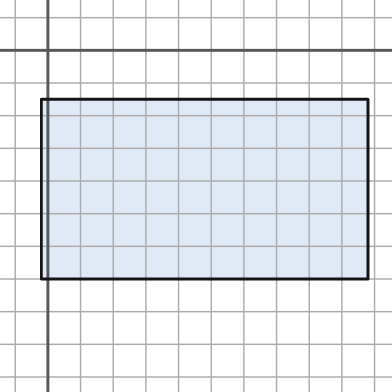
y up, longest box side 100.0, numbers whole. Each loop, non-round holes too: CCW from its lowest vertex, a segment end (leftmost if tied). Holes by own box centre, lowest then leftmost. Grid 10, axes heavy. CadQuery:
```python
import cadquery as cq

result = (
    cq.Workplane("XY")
    .moveTo(-2.0, -70.0)
    .lineTo(98.0, -70.0)
    .lineTo(98.0, -15.0)
    .lineTo(-2.0, -15.0)
    .close()
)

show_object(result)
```